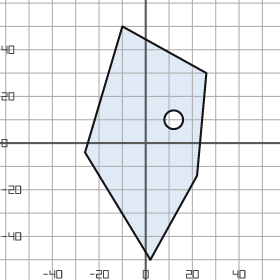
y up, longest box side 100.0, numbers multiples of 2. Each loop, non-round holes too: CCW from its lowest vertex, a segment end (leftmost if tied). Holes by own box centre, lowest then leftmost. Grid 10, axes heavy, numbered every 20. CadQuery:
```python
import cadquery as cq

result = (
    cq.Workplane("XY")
    .moveTo(2.0, -50.0)
    .lineTo(22.0, -14.0)
    .lineTo(26.0, 30.0)
    .lineTo(-10.0, 50.0)
    .lineTo(-26.0, -4.0)
    .close()
    .moveTo(12.0, 10.0)
    .circle(4.0)
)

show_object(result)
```